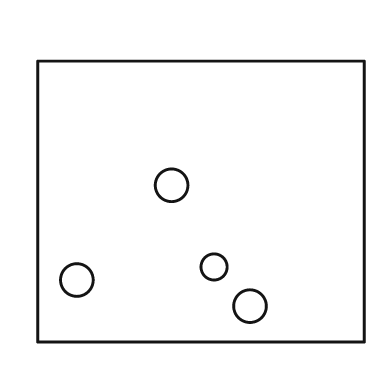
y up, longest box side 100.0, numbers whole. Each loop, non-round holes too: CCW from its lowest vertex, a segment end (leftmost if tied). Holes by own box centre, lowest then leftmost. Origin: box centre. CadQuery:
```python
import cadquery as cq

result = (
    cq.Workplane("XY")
    .moveTo(-50.0, -43.0)
    .lineTo(50.0, -43.0)
    .lineTo(50.0, 43.0)
    .lineTo(-50.0, 43.0)
    .close()
    .moveTo(15.0, -32.0)
    .circle(5.0)
    .moveTo(-38.0, -24.0)
    .circle(5.0)
    .moveTo(4.0, -20.0)
    .circle(4.0)
    .moveTo(-9.0, 5.0)
    .circle(5.0)
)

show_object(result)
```